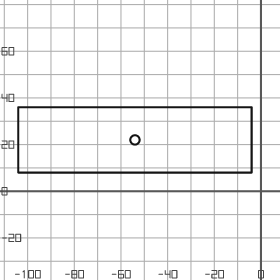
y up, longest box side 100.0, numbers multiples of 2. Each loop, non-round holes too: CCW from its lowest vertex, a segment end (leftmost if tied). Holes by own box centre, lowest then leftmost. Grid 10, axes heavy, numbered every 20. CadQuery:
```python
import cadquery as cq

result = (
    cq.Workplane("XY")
    .moveTo(-104.0, 8.0)
    .lineTo(-4.0, 8.0)
    .lineTo(-4.0, 36.0)
    .lineTo(-104.0, 36.0)
    .close()
    .moveTo(-54.0, 22.0)
    .circle(2.0)
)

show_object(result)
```